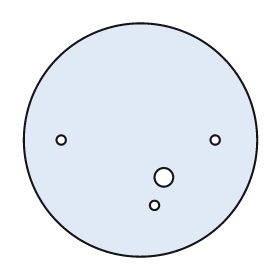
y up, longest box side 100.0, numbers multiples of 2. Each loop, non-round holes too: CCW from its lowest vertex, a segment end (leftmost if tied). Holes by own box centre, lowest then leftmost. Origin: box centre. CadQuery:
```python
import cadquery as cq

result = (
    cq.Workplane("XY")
    .moveTo(0.0, 0.0)
    .circle(50.0)
    .moveTo(6.0, -28.0)
    .circle(2.0)
    .moveTo(10.0, -16.0)
    .circle(4.0)
    .moveTo(-34.0, 0.0)
    .circle(2.0)
    .moveTo(32.0, 0.0)
    .circle(2.0)
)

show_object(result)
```